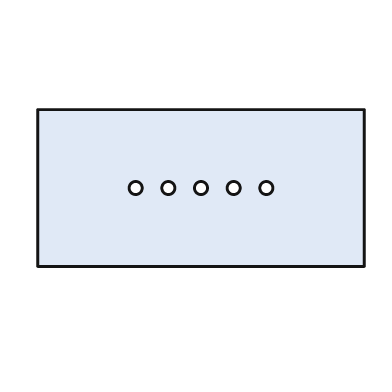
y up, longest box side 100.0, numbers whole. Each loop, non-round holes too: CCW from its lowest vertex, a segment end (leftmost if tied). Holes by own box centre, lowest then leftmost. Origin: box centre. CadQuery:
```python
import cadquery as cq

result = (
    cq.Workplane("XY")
    .moveTo(-50.0, -24.0)
    .lineTo(50.0, -24.0)
    .lineTo(50.0, 24.0)
    .lineTo(-50.0, 24.0)
    .close()
    .moveTo(-20.0, 0.0)
    .circle(2.0)
    .moveTo(-10.0, 0.0)
    .circle(2.0)
    .moveTo(0.0, 0.0)
    .circle(2.0)
    .moveTo(10.0, 0.0)
    .circle(2.0)
    .moveTo(20.0, 0.0)
    .circle(2.0)
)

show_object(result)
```